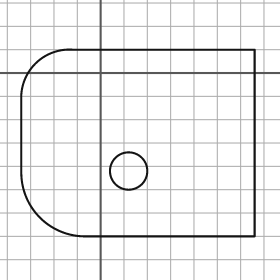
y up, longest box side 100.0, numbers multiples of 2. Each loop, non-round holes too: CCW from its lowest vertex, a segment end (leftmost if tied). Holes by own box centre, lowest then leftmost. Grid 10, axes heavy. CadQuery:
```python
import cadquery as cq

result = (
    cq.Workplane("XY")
    .moveTo(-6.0, -70.0)
    .lineTo(66.0, -70.0)
    .lineTo(66.0, 10.0)
    .lineTo(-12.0, 10.0)
    .threePointArc((-28.0, 4.0), (-34.0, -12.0))
    .lineTo(-34.0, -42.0)
    .threePointArc((-26.0, -62.0), (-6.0, -70.0))
    .close()
    .moveTo(12.0, -42.0)
    .circle(8.0)
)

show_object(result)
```